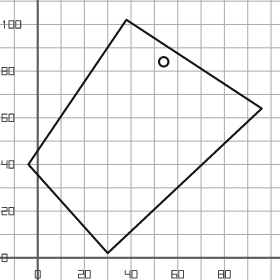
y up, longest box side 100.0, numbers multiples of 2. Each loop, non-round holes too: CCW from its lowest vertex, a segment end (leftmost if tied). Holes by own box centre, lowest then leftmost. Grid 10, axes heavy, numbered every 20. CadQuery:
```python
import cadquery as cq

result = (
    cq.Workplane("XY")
    .moveTo(30.0, 2.0)
    .lineTo(96.0, 64.0)
    .lineTo(38.0, 102.0)
    .lineTo(-4.0, 40.0)
    .close()
    .moveTo(54.0, 84.0)
    .circle(2.0)
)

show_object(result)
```